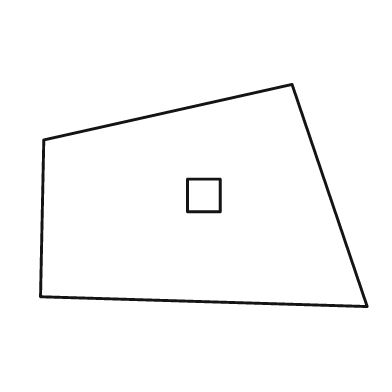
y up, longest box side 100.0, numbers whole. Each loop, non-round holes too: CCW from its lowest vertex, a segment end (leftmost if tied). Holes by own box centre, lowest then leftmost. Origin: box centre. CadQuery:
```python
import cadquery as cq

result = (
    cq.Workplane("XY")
    .moveTo(50.0, -34.0)
    .lineTo(27.0, 34.0)
    .lineTo(-49.0, 17.0)
    .lineTo(-50.0, -31.0)
    .close()
    .moveTo(-5.0, -5.0)
    .lineTo(5.0, -5.0)
    .lineTo(5.0, 5.0)
    .lineTo(-5.0, 5.0)
    .close()
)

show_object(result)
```